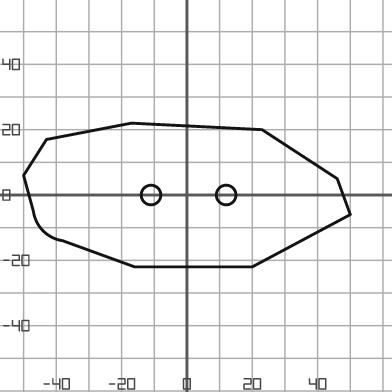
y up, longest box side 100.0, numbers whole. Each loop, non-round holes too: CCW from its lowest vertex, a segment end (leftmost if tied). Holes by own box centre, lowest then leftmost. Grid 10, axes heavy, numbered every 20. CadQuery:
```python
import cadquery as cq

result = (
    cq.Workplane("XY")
    .moveTo(-16.0, -22.0)
    .lineTo(20.0, -22.0)
    .lineTo(50.0, -6.0)
    .lineTo(46.0, 5.0)
    .lineTo(23.0, 20.0)
    .lineTo(-17.0, 22.0)
    .lineTo(-43.0, 17.0)
    .lineTo(-50.0, 6.0)
    .lineTo(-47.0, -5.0)
    .threePointArc((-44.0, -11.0), (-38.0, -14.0))
    .close()
    .moveTo(-11.0, 0.0)
    .circle(3.0)
    .moveTo(12.0, 0.0)
    .circle(3.0)
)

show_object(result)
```